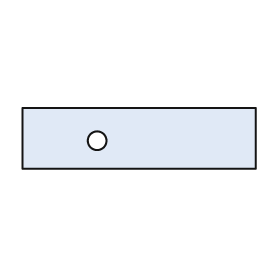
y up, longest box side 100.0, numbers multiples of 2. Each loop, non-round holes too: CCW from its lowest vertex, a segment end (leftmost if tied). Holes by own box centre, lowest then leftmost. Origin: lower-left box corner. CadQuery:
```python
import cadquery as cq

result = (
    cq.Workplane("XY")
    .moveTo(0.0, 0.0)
    .lineTo(100.0, 0.0)
    .lineTo(100.0, 26.0)
    .lineTo(0.0, 26.0)
    .close()
    .moveTo(32.0, 12.0)
    .circle(4.0)
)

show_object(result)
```